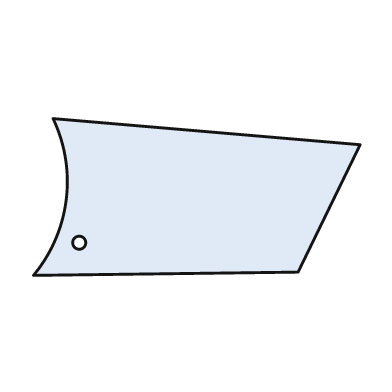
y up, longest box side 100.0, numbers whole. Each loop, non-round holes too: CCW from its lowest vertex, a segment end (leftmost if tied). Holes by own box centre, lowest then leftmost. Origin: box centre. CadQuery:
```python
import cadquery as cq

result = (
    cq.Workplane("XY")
    .moveTo(-50.0, -24.0)
    .lineTo(31.0, -23.0)
    .lineTo(50.0, 16.0)
    .lineTo(-44.0, 24.0)
    .threePointArc((-40.0, -1.0), (-50.0, -24.0))
    .close()
    .moveTo(-36.0, -14.0)
    .circle(2.0)
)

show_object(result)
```